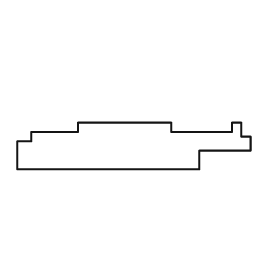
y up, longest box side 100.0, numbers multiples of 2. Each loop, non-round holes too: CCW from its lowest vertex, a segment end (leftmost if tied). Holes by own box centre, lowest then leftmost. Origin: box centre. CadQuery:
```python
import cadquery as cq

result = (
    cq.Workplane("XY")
    .moveTo(-50.0, -10.0)
    .lineTo(28.0, -10.0)
    .lineTo(28.0, -2.0)
    .lineTo(50.0, -2.0)
    .lineTo(50.0, 4.0)
    .lineTo(46.0, 4.0)
    .lineTo(46.0, 10.0)
    .lineTo(42.0, 10.0)
    .lineTo(42.0, 6.0)
    .lineTo(16.0, 6.0)
    .lineTo(16.0, 10.0)
    .lineTo(-24.0, 10.0)
    .lineTo(-24.0, 6.0)
    .lineTo(-44.0, 6.0)
    .lineTo(-44.0, 2.0)
    .lineTo(-50.0, 2.0)
    .close()
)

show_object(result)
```